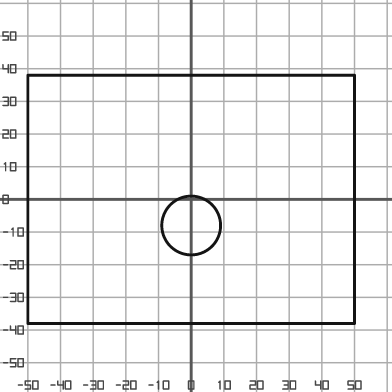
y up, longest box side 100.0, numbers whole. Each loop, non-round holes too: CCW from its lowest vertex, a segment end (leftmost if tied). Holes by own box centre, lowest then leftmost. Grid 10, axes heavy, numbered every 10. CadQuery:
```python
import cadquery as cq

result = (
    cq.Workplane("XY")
    .moveTo(-50.0, -38.0)
    .lineTo(50.0, -38.0)
    .lineTo(50.0, 38.0)
    .lineTo(-50.0, 38.0)
    .close()
    .moveTo(0.0, -8.0)
    .circle(9.0)
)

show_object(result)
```